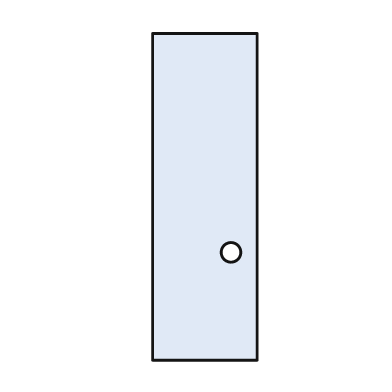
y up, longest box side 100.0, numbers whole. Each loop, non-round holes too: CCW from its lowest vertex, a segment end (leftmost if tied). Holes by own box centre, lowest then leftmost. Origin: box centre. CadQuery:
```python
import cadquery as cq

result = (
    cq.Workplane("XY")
    .moveTo(-16.0, -50.0)
    .lineTo(16.0, -50.0)
    .lineTo(16.0, 50.0)
    .lineTo(-16.0, 50.0)
    .close()
    .moveTo(8.0, -17.0)
    .circle(3.0)
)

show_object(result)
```